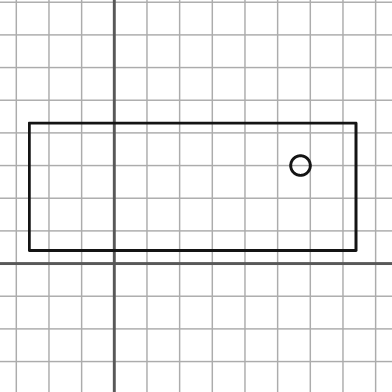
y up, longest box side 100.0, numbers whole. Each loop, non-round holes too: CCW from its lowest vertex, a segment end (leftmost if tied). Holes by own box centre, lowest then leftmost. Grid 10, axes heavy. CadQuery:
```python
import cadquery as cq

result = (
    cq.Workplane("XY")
    .moveTo(-26.0, 4.0)
    .lineTo(74.0, 4.0)
    .lineTo(74.0, 43.0)
    .lineTo(-26.0, 43.0)
    .close()
    .moveTo(57.0, 30.0)
    .circle(3.0)
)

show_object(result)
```